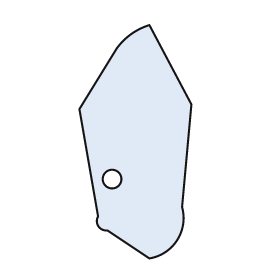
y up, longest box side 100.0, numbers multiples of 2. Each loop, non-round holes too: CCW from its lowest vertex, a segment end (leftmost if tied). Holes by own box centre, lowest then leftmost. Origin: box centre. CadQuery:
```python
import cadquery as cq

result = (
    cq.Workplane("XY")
    .moveTo(6.0, -50.0)
    .threePointArc((18.0, -42.0), (20.0, -28.0))
    .lineTo(24.0, 16.0)
    .lineTo(6.0, 50.0)
    .threePointArc((-2.0, 46.0), (-8.0, 40.0))
    .lineTo(-24.0, 14.0)
    .lineTo(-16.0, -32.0)
    .threePointArc((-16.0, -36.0), (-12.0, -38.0))
    .close()
    .moveTo(-10.0, -16.0)
    .circle(4.0)
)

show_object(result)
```